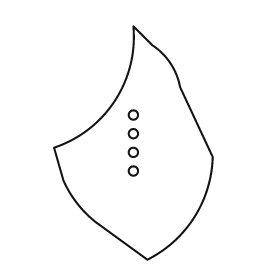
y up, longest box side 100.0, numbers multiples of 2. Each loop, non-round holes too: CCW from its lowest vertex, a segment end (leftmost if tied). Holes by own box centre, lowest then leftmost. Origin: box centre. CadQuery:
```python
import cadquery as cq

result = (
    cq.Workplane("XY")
    .moveTo(6.0, -50.0)
    .threePointArc((26.0, -32.0), (34.0, -6.0))
    .lineTo(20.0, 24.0)
    .threePointArc((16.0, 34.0), (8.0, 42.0))
    .lineTo(0.0, 50.0)
    .threePointArc((-8.0, 18.0), (-34.0, -2.0))
    .lineTo(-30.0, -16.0)
    .threePointArc((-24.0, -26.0), (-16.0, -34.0))
    .close()
    .moveTo(0.0, -12.0)
    .circle(2.0)
    .moveTo(0.0, -4.0)
    .circle(2.0)
    .moveTo(0.0, 4.0)
    .circle(2.0)
    .moveTo(0.0, 12.0)
    .circle(2.0)
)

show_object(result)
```